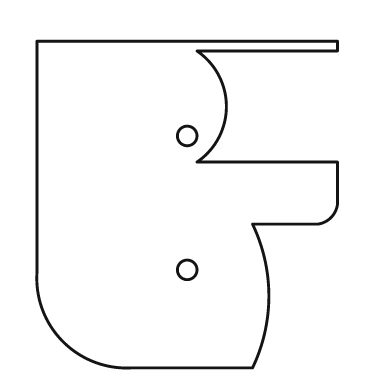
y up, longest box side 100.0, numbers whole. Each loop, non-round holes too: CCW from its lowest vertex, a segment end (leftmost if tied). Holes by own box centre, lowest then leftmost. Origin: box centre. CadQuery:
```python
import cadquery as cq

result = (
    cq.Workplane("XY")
    .moveTo(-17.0, -50.0)
    .lineTo(20.0, -50.0)
    .threePointArc((25.0, -28.0), (20.0, -6.0))
    .lineTo(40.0, -6.0)
    .threePointArc((44.0, -4.0), (46.0, 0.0))
    .lineTo(46.0, 13.0)
    .lineTo(3.0, 13.0)
    .threePointArc((12.0, 30.0), (3.0, 47.0))
    .lineTo(46.0, 47.0)
    .lineTo(46.0, 50.0)
    .lineTo(-46.0, 50.0)
    .lineTo(-46.0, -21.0)
    .threePointArc((-38.0, -42.0), (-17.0, -50.0))
    .close()
    .moveTo(0.0, -20.0)
    .circle(3.0)
    .moveTo(0.0, 21.0)
    .circle(3.0)
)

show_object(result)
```